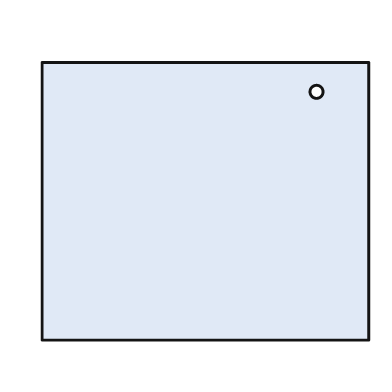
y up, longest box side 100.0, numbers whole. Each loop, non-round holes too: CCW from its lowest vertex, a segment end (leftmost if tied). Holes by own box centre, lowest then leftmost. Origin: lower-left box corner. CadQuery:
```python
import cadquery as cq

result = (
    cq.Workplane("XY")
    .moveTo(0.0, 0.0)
    .lineTo(100.0, 0.0)
    .lineTo(100.0, 85.0)
    .lineTo(0.0, 85.0)
    .close()
    .moveTo(84.0, 76.0)
    .circle(2.0)
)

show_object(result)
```